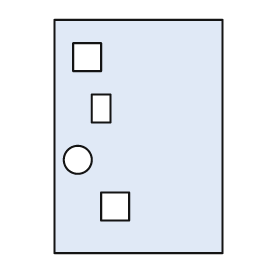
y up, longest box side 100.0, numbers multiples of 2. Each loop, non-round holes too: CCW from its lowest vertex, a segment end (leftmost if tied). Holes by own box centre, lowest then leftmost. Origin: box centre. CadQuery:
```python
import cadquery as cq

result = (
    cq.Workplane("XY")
    .moveTo(-36.0, -50.0)
    .lineTo(36.0, -50.0)
    .lineTo(36.0, 50.0)
    .lineTo(-36.0, 50.0)
    .close()
    .moveTo(-16.0, -36.0)
    .lineTo(-4.0, -36.0)
    .lineTo(-4.0, -24.0)
    .lineTo(-16.0, -24.0)
    .close()
    .moveTo(-26.0, -10.0)
    .circle(6.0)
    .moveTo(-20.0, 6.0)
    .lineTo(-12.0, 6.0)
    .lineTo(-12.0, 18.0)
    .lineTo(-20.0, 18.0)
    .close()
    .moveTo(-28.0, 28.0)
    .lineTo(-16.0, 28.0)
    .lineTo(-16.0, 40.0)
    .lineTo(-28.0, 40.0)
    .close()
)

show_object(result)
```